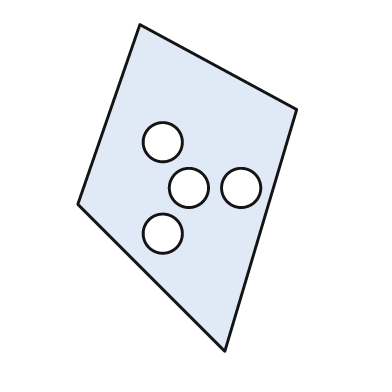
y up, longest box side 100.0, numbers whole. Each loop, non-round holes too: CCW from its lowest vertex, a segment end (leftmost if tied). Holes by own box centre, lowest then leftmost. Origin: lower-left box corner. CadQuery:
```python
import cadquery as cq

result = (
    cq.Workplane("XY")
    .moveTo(45.0, 0.0)
    .lineTo(67.0, 74.0)
    .lineTo(19.0, 100.0)
    .lineTo(0.0, 45.0)
    .close()
    .moveTo(26.0, 36.0)
    .circle(6.0)
    .moveTo(34.0, 50.0)
    .circle(6.0)
    .moveTo(50.0, 50.0)
    .circle(6.0)
    .moveTo(26.0, 64.0)
    .circle(6.0)
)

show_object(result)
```